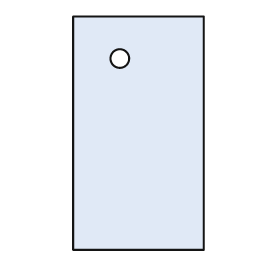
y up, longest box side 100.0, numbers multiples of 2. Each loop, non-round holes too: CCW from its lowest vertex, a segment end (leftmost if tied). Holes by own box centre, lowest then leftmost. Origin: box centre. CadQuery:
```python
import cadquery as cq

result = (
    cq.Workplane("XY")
    .moveTo(-28.0, -50.0)
    .lineTo(28.0, -50.0)
    .lineTo(28.0, 50.0)
    .lineTo(-28.0, 50.0)
    .close()
    .moveTo(-8.0, 32.0)
    .circle(4.0)
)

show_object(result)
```